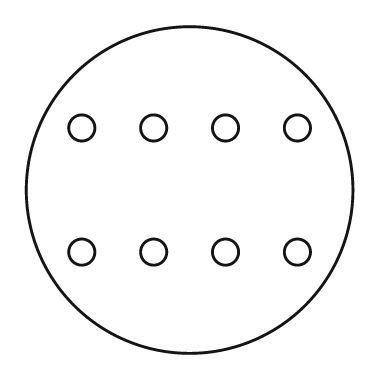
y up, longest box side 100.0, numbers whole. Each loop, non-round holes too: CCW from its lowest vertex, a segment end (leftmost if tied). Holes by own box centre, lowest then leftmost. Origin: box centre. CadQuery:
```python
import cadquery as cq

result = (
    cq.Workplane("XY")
    .moveTo(0.0, 0.0)
    .circle(50.0)
    .moveTo(-33.0, -19.0)
    .circle(4.0)
    .moveTo(-11.0, -19.0)
    .circle(4.0)
    .moveTo(11.0, -19.0)
    .circle(4.0)
    .moveTo(33.0, -19.0)
    .circle(4.0)
    .moveTo(-33.0, 19.0)
    .circle(4.0)
    .moveTo(-11.0, 19.0)
    .circle(4.0)
    .moveTo(11.0, 19.0)
    .circle(4.0)
    .moveTo(33.0, 19.0)
    .circle(4.0)
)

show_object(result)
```